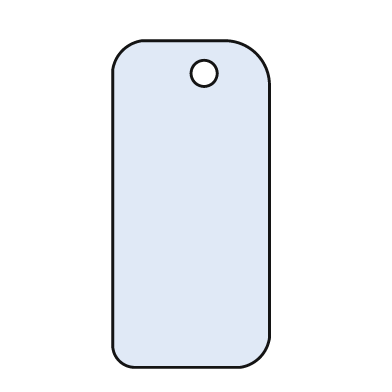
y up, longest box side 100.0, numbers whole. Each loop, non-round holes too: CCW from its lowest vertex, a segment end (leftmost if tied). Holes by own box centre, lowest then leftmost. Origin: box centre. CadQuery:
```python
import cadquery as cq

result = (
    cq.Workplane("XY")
    .moveTo(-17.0, -50.0)
    .lineTo(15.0, -50.0)
    .threePointArc((21.0, -47.0), (24.0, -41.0))
    .lineTo(24.0, 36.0)
    .threePointArc((20.0, 46.0), (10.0, 50.0))
    .lineTo(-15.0, 50.0)
    .threePointArc((-21.0, 47.0), (-24.0, 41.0))
    .lineTo(-24.0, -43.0)
    .threePointArc((-22.0, -48.0), (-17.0, -50.0))
    .close()
    .moveTo(4.0, 40.0)
    .circle(4.0)
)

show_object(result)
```